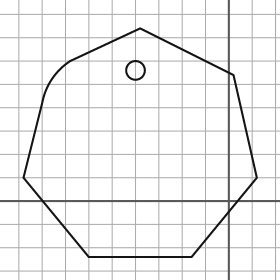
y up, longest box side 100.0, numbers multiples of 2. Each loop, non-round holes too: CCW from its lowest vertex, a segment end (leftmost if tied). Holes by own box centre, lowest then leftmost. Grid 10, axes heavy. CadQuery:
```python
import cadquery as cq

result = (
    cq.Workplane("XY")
    .moveTo(-60.0, -24.0)
    .lineTo(-16.0, -24.0)
    .lineTo(12.0, 10.0)
    .lineTo(2.0, 54.0)
    .lineTo(-38.0, 74.0)
    .lineTo(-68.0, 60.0)
    .threePointArc((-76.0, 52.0), (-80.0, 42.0))
    .lineTo(-88.0, 10.0)
    .close()
    .moveTo(-40.0, 56.0)
    .circle(4.0)
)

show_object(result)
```